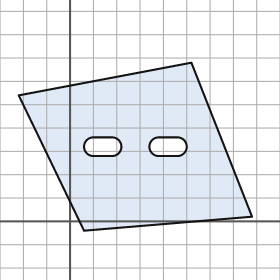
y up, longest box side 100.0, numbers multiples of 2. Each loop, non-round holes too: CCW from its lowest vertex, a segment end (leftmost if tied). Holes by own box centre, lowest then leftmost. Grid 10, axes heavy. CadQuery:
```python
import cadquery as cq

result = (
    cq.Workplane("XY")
    .moveTo(6.0, -4.0)
    .lineTo(78.0, 2.0)
    .lineTo(52.0, 68.0)
    .lineTo(-22.0, 54.0)
    .close()
    .moveTo(10.0, 28.0)
    .lineTo(18.0, 28.0)
    .threePointArc((22.0, 32.0), (18.0, 36.0))
    .lineTo(10.0, 36.0)
    .threePointArc((6.0, 32.0), (10.0, 28.0))
    .close()
    .moveTo(38.0, 28.0)
    .lineTo(46.0, 28.0)
    .threePointArc((50.0, 32.0), (46.0, 36.0))
    .lineTo(38.0, 36.0)
    .threePointArc((34.0, 32.0), (38.0, 28.0))
    .close()
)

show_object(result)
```